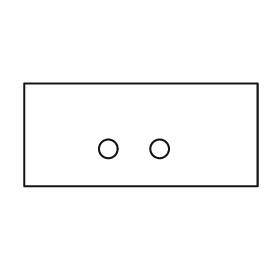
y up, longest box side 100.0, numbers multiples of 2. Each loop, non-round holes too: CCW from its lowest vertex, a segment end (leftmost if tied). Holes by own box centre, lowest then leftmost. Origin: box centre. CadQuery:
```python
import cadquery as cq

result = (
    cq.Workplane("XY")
    .moveTo(-50.0, -22.0)
    .lineTo(50.0, -22.0)
    .lineTo(50.0, 22.0)
    .lineTo(-50.0, 22.0)
    .close()
    .moveTo(-14.0, -6.0)
    .circle(4.0)
    .moveTo(8.0, -6.0)
    .circle(4.0)
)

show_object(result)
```